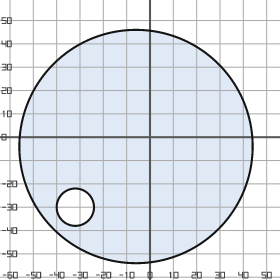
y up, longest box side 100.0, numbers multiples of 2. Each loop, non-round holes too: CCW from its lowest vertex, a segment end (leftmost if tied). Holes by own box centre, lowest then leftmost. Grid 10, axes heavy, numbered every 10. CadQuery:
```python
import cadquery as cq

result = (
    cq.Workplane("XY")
    .moveTo(-6.0, -4.0)
    .circle(50.0)
    .moveTo(-32.0, -30.0)
    .circle(8.0)
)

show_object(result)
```